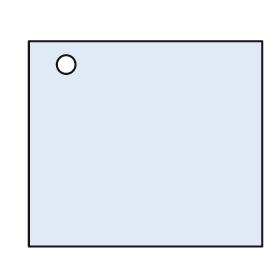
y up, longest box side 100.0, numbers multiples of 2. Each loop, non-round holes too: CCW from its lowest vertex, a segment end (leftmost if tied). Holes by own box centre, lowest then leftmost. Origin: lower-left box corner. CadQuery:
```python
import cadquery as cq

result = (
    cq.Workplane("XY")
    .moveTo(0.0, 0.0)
    .lineTo(100.0, 0.0)
    .lineTo(100.0, 88.0)
    .lineTo(0.0, 88.0)
    .close()
    .moveTo(16.0, 78.0)
    .circle(4.0)
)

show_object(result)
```